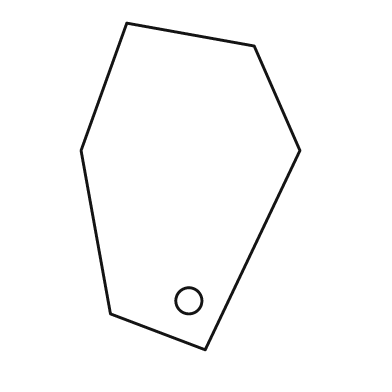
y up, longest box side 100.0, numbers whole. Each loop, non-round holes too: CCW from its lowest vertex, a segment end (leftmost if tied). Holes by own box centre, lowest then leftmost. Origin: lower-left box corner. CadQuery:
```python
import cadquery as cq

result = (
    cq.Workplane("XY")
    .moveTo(38.0, 0.0)
    .lineTo(67.0, 61.0)
    .lineTo(53.0, 93.0)
    .lineTo(14.0, 100.0)
    .lineTo(0.0, 61.0)
    .lineTo(9.0, 11.0)
    .close()
    .moveTo(33.0, 15.0)
    .circle(4.0)
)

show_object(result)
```